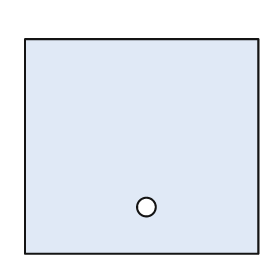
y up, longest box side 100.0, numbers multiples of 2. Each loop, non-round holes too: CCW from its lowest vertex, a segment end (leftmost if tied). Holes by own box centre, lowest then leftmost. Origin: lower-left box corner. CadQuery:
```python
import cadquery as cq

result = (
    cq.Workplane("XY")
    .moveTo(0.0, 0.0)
    .lineTo(100.0, 0.0)
    .lineTo(100.0, 92.0)
    .lineTo(0.0, 92.0)
    .close()
    .moveTo(52.0, 20.0)
    .circle(4.0)
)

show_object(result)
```